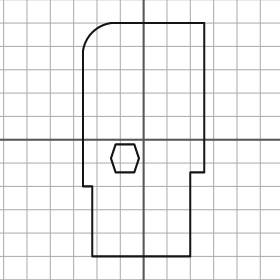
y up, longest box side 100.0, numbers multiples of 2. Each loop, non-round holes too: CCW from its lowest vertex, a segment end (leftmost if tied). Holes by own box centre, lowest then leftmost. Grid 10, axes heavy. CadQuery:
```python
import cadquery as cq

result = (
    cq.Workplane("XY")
    .moveTo(-22.0, -50.0)
    .lineTo(20.0, -50.0)
    .lineTo(20.0, -14.0)
    .lineTo(26.0, -14.0)
    .lineTo(26.0, 50.0)
    .lineTo(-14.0, 50.0)
    .threePointArc((-22.0, 46.0), (-26.0, 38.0))
    .lineTo(-26.0, -20.0)
    .lineTo(-22.0, -20.0)
    .close()
    .moveTo(-12.0, -14.0)
    .lineTo(-4.0, -14.0)
    .lineTo(-2.0, -8.0)
    .lineTo(-4.0, -2.0)
    .lineTo(-12.0, -2.0)
    .lineTo(-14.0, -8.0)
    .close()
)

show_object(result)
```